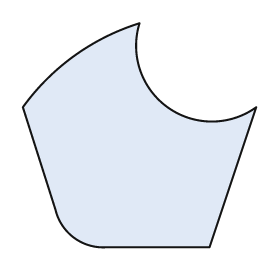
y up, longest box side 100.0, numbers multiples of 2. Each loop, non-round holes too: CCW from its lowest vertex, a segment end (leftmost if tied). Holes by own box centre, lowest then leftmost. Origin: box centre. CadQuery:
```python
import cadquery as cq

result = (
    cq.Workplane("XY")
    .moveTo(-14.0, -48.0)
    .lineTo(30.0, -48.0)
    .lineTo(50.0, 12.0)
    .threePointArc((12.0, 12.0), (0.0, 48.0))
    .threePointArc((-28.0, 34.0), (-50.0, 12.0))
    .lineTo(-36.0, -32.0)
    .threePointArc((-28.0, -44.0), (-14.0, -48.0))
    .close()
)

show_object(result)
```